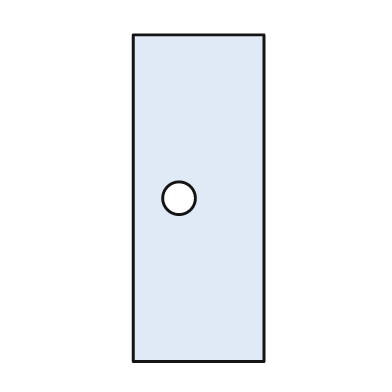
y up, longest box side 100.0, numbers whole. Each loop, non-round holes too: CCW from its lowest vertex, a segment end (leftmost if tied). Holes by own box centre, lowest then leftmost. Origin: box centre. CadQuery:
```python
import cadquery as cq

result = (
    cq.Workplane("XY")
    .moveTo(-20.0, -50.0)
    .lineTo(20.0, -50.0)
    .lineTo(20.0, 50.0)
    .lineTo(-20.0, 50.0)
    .close()
    .moveTo(-6.0, 0.0)
    .circle(5.0)
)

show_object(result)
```